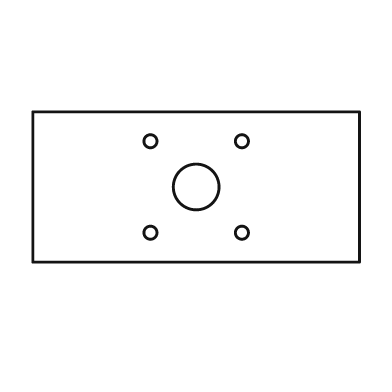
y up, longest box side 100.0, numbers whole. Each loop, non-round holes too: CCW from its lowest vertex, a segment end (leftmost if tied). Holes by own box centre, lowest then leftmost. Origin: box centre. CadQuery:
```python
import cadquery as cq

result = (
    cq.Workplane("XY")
    .moveTo(-50.0, -23.0)
    .lineTo(50.0, -23.0)
    .lineTo(50.0, 23.0)
    .lineTo(-50.0, 23.0)
    .close()
    .moveTo(-14.0, -14.0)
    .circle(2.0)
    .moveTo(14.0, -14.0)
    .circle(2.0)
    .moveTo(0.0, 0.0)
    .circle(7.0)
    .moveTo(-14.0, 14.0)
    .circle(2.0)
    .moveTo(14.0, 14.0)
    .circle(2.0)
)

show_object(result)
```